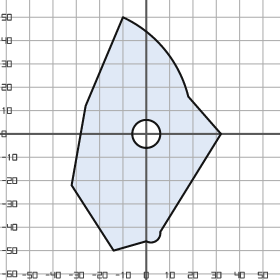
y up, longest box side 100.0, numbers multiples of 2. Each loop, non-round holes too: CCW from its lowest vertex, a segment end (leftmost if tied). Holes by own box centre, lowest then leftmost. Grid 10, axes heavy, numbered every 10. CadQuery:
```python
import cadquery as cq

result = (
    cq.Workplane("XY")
    .moveTo(-14.0, -50.0)
    .lineTo(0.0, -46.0)
    .threePointArc((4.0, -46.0), (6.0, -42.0))
    .lineTo(32.0, 0.0)
    .lineTo(18.0, 16.0)
    .threePointArc((8.0, 36.0), (-10.0, 50.0))
    .lineTo(-26.0, 12.0)
    .lineTo(-32.0, -22.0)
    .close()
    .moveTo(0.0, 0.0)
    .circle(6.0)
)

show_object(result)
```